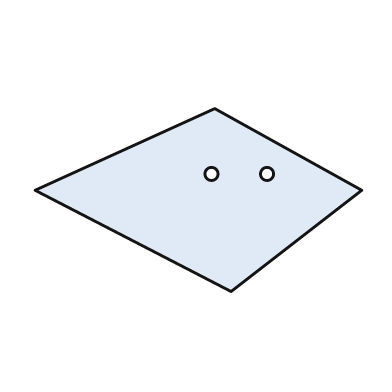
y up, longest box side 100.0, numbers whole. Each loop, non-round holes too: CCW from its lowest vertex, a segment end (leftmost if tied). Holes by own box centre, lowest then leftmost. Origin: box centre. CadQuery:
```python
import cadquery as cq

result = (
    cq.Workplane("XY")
    .moveTo(10.0, -28.0)
    .lineTo(50.0, 3.0)
    .lineTo(5.0, 28.0)
    .lineTo(-50.0, 3.0)
    .close()
    .moveTo(4.0, 8.0)
    .circle(2.0)
    .moveTo(21.0, 8.0)
    .circle(2.0)
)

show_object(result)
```